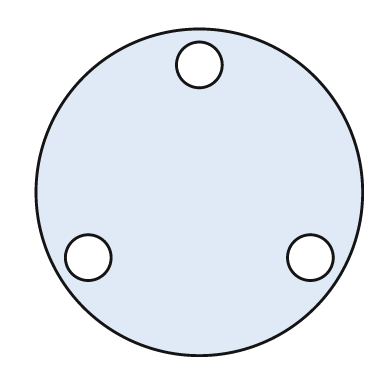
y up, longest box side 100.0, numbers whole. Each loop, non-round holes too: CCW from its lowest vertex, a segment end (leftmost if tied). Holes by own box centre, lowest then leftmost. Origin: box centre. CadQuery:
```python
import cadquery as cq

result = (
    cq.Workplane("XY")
    .moveTo(0.0, 0.0)
    .circle(50.0)
    .moveTo(-34.0, -20.0)
    .circle(7.0)
    .moveTo(34.0, -20.0)
    .circle(7.0)
    .moveTo(0.0, 39.0)
    .circle(7.0)
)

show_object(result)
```